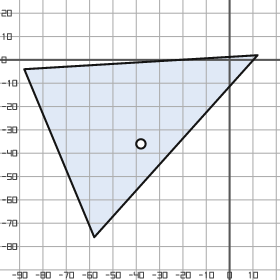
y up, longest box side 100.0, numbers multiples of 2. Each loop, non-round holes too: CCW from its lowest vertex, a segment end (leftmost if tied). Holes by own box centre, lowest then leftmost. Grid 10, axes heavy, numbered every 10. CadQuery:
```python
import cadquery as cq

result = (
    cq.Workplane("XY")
    .moveTo(-58.0, -76.0)
    .lineTo(12.0, 2.0)
    .lineTo(-88.0, -4.0)
    .close()
    .moveTo(-38.0, -36.0)
    .circle(2.0)
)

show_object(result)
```